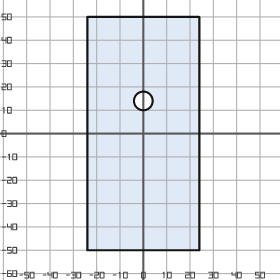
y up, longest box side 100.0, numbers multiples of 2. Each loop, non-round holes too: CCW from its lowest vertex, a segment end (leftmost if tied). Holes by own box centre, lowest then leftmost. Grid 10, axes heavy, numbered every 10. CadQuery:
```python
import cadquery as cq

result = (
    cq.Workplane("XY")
    .moveTo(-24.0, -50.0)
    .lineTo(24.0, -50.0)
    .lineTo(24.0, 50.0)
    .lineTo(-24.0, 50.0)
    .close()
    .moveTo(0.0, 14.0)
    .circle(4.0)
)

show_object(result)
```